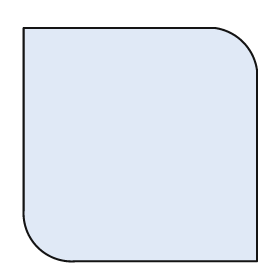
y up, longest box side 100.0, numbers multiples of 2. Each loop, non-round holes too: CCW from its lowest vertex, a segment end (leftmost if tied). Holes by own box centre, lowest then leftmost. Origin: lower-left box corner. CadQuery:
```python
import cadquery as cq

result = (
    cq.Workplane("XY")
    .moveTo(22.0, 0.0)
    .lineTo(100.0, 0.0)
    .lineTo(100.0, 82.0)
    .threePointArc((94.0, 94.0), (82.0, 100.0))
    .lineTo(0.0, 100.0)
    .lineTo(0.0, 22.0)
    .threePointArc((6.0, 6.0), (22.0, 0.0))
    .close()
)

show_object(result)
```